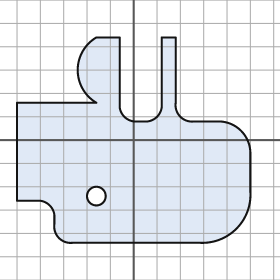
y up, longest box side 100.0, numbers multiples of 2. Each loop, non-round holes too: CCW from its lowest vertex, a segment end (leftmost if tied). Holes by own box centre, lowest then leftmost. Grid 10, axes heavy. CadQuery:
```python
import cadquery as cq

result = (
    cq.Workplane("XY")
    .moveTo(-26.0, -44.0)
    .lineTo(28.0, -44.0)
    .threePointArc((44.0, -38.0), (50.0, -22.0))
    .lineTo(50.0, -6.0)
    .threePointArc((46.0, 4.0), (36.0, 8.0))
    .lineTo(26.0, 8.0)
    .threePointArc((20.0, 10.0), (18.0, 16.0))
    .lineTo(18.0, 44.0)
    .lineTo(12.0, 44.0)
    .lineTo(12.0, 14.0)
    .threePointArc((10.0, 10.0), (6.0, 8.0))
    .lineTo(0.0, 8.0)
    .threePointArc((-4.0, 10.0), (-6.0, 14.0))
    .lineTo(-6.0, 44.0)
    .lineTo(-16.0, 44.0)
    .threePointArc((-24.0, 30.0), (-16.0, 16.0))
    .lineTo(-50.0, 16.0)
    .lineTo(-50.0, -26.0)
    .lineTo(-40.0, -26.0)
    .threePointArc((-36.0, -28.0), (-34.0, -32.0))
    .lineTo(-34.0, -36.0)
    .threePointArc((-32.0, -42.0), (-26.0, -44.0))
    .close()
    .moveTo(-16.0, -24.0)
    .circle(4.0)
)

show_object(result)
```